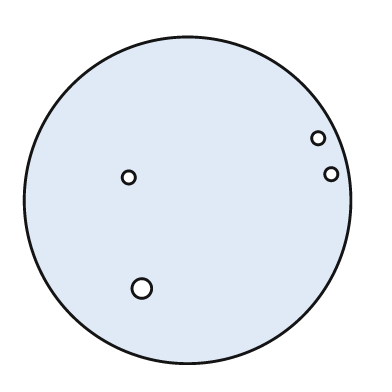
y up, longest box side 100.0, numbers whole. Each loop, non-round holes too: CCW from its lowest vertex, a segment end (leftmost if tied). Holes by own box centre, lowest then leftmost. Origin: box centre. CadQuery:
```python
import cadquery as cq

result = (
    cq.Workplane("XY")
    .moveTo(0.0, 0.0)
    .circle(50.0)
    .moveTo(-14.0, -27.0)
    .circle(3.0)
    .moveTo(-18.0, 7.0)
    .circle(2.0)
    .moveTo(44.0, 8.0)
    .circle(2.0)
    .moveTo(40.0, 19.0)
    .circle(2.0)
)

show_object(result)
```